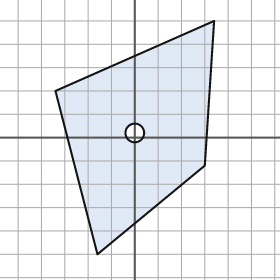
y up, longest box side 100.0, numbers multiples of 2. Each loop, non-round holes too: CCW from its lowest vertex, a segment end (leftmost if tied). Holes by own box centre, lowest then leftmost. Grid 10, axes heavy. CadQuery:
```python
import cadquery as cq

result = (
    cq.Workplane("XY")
    .moveTo(-16.0, -50.0)
    .lineTo(30.0, -12.0)
    .lineTo(34.0, 50.0)
    .lineTo(-34.0, 20.0)
    .close()
    .moveTo(0.0, 2.0)
    .circle(4.0)
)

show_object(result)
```